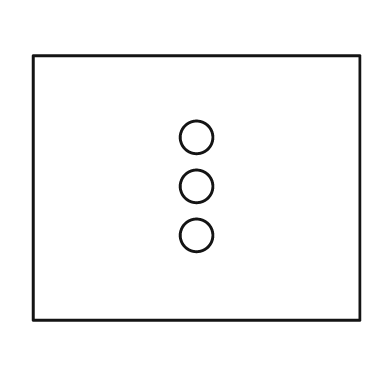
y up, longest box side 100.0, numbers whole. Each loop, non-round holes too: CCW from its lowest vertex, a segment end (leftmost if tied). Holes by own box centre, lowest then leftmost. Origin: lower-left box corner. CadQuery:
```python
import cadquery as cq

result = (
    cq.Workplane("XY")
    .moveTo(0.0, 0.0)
    .lineTo(100.0, 0.0)
    .lineTo(100.0, 81.0)
    .lineTo(0.0, 81.0)
    .close()
    .moveTo(50.0, 26.0)
    .circle(5.0)
    .moveTo(50.0, 41.0)
    .circle(5.0)
    .moveTo(50.0, 56.0)
    .circle(5.0)
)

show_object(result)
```